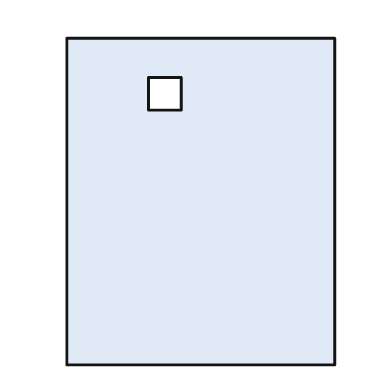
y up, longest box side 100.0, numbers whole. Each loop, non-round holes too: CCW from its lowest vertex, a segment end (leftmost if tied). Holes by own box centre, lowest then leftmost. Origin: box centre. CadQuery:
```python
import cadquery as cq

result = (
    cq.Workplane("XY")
    .moveTo(-41.0, -50.0)
    .lineTo(41.0, -50.0)
    .lineTo(41.0, 50.0)
    .lineTo(-41.0, 50.0)
    .close()
    .moveTo(-16.0, 28.0)
    .lineTo(-6.0, 28.0)
    .lineTo(-6.0, 38.0)
    .lineTo(-16.0, 38.0)
    .close()
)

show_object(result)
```